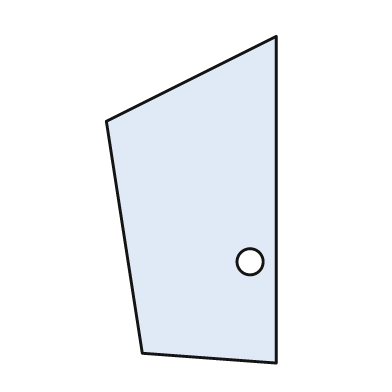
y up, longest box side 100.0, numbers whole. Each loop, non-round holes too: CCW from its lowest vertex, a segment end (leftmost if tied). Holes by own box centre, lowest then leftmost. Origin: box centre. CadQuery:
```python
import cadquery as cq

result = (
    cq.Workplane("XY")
    .moveTo(26.0, -50.0)
    .lineTo(26.0, 50.0)
    .lineTo(-26.0, 24.0)
    .lineTo(-15.0, -47.0)
    .close()
    .moveTo(18.0, -19.0)
    .circle(4.0)
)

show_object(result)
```